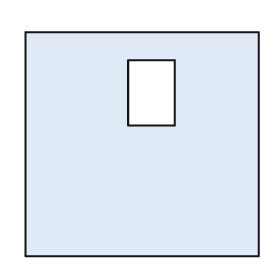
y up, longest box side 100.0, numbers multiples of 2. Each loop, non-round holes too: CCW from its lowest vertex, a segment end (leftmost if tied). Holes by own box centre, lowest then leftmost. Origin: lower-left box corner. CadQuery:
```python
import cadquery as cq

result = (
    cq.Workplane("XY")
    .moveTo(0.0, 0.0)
    .lineTo(100.0, 0.0)
    .lineTo(100.0, 96.0)
    .lineTo(0.0, 96.0)
    .close()
    .moveTo(44.0, 56.0)
    .lineTo(64.0, 56.0)
    .lineTo(64.0, 84.0)
    .lineTo(44.0, 84.0)
    .close()
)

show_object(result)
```